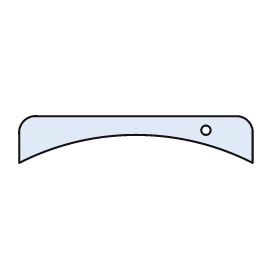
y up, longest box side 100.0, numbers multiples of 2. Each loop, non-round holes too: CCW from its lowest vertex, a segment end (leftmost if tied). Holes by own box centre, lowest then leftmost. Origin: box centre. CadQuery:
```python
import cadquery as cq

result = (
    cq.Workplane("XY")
    .moveTo(-50.0, -10.0)
    .threePointArc((0.0, 2.0), (50.0, -10.0))
    .lineTo(50.0, 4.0)
    .threePointArc((48.0, 8.0), (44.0, 10.0))
    .lineTo(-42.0, 10.0)
    .threePointArc((-48.0, 8.0), (-50.0, 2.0))
    .close()
    .moveTo(30.0, 4.0)
    .circle(2.0)
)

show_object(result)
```